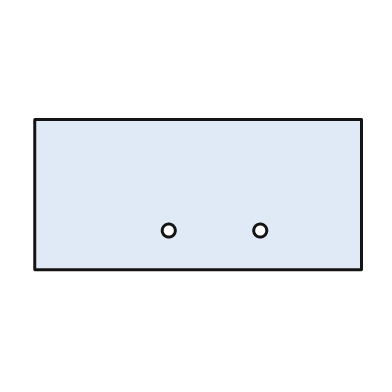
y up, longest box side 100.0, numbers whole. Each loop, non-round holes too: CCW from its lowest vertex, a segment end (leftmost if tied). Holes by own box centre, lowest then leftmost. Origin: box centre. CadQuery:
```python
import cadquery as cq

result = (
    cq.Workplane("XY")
    .moveTo(-50.0, -23.0)
    .lineTo(50.0, -23.0)
    .lineTo(50.0, 23.0)
    .lineTo(-50.0, 23.0)
    .close()
    .moveTo(-9.0, -11.0)
    .circle(2.0)
    .moveTo(19.0, -11.0)
    .circle(2.0)
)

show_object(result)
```